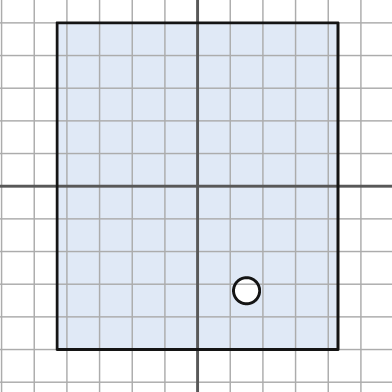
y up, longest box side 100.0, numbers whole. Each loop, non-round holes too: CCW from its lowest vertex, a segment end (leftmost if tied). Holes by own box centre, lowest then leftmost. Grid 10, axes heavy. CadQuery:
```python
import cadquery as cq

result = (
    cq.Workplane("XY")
    .moveTo(-43.0, -50.0)
    .lineTo(43.0, -50.0)
    .lineTo(43.0, 50.0)
    .lineTo(-43.0, 50.0)
    .close()
    .moveTo(15.0, -32.0)
    .circle(4.0)
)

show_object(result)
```